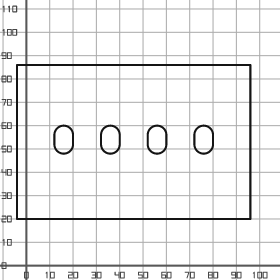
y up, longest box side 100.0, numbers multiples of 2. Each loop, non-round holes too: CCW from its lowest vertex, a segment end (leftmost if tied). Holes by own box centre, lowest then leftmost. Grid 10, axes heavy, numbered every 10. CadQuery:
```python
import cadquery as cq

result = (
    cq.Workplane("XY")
    .moveTo(-4.0, 20.0)
    .lineTo(96.0, 20.0)
    .lineTo(96.0, 86.0)
    .lineTo(-4.0, 86.0)
    .close()
    .moveTo(12.0, 52.0)
    .threePointArc((16.0, 48.0), (20.0, 52.0))
    .lineTo(20.0, 56.0)
    .threePointArc((16.0, 60.0), (12.0, 56.0))
    .close()
    .moveTo(32.0, 52.0)
    .threePointArc((36.0, 48.0), (40.0, 52.0))
    .lineTo(40.0, 56.0)
    .threePointArc((36.0, 60.0), (32.0, 56.0))
    .close()
    .moveTo(52.0, 52.0)
    .threePointArc((56.0, 48.0), (60.0, 52.0))
    .lineTo(60.0, 56.0)
    .threePointArc((56.0, 60.0), (52.0, 56.0))
    .close()
    .moveTo(72.0, 52.0)
    .threePointArc((76.0, 48.0), (80.0, 52.0))
    .lineTo(80.0, 56.0)
    .threePointArc((76.0, 60.0), (72.0, 56.0))
    .close()
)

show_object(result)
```